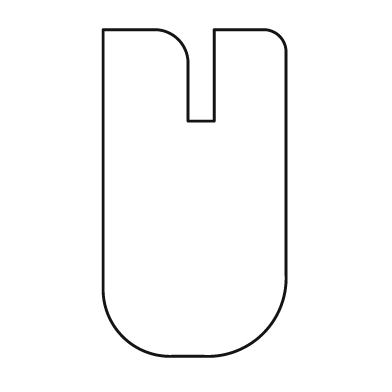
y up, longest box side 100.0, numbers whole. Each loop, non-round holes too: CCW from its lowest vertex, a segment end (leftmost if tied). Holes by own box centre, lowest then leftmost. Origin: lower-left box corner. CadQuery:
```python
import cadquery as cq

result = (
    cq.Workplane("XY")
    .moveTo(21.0, 0.0)
    .lineTo(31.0, 0.0)
    .threePointArc((49.0, 7.0), (56.0, 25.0))
    .lineTo(56.0, 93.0)
    .threePointArc((54.0, 98.0), (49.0, 100.0))
    .lineTo(34.0, 100.0)
    .lineTo(34.0, 72.0)
    .lineTo(26.0, 72.0)
    .lineTo(26.0, 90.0)
    .threePointArc((23.0, 97.0), (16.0, 100.0))
    .lineTo(0.0, 100.0)
    .lineTo(0.0, 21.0)
    .threePointArc((6.0, 6.0), (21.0, 0.0))
    .close()
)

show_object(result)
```